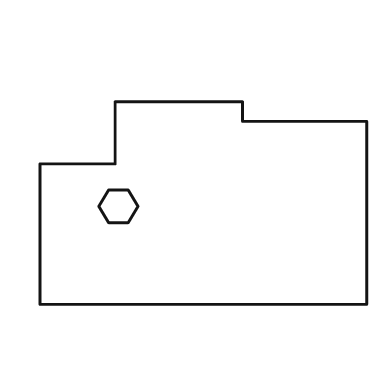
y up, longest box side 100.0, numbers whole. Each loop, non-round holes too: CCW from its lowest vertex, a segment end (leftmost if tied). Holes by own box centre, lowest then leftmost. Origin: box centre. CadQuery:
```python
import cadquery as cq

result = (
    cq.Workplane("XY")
    .moveTo(-50.0, -31.0)
    .lineTo(50.0, -31.0)
    .lineTo(50.0, 25.0)
    .lineTo(12.0, 25.0)
    .lineTo(12.0, 31.0)
    .lineTo(-27.0, 31.0)
    .lineTo(-27.0, 12.0)
    .lineTo(-50.0, 12.0)
    .close()
    .moveTo(-29.0, -6.0)
    .lineTo(-23.0, -6.0)
    .lineTo(-20.0, -1.0)
    .lineTo(-23.0, 4.0)
    .lineTo(-29.0, 4.0)
    .lineTo(-32.0, -1.0)
    .close()
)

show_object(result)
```